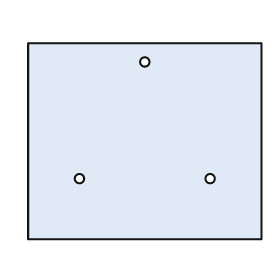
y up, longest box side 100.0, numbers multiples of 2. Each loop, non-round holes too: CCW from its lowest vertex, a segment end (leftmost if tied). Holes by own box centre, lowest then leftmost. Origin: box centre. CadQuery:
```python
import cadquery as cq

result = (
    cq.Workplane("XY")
    .moveTo(-50.0, -42.0)
    .lineTo(50.0, -42.0)
    .lineTo(50.0, 42.0)
    .lineTo(-50.0, 42.0)
    .close()
    .moveTo(-28.0, -16.0)
    .circle(2.0)
    .moveTo(28.0, -16.0)
    .circle(2.0)
    .moveTo(0.0, 34.0)
    .circle(2.0)
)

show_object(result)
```